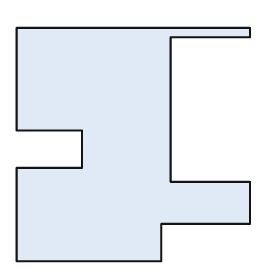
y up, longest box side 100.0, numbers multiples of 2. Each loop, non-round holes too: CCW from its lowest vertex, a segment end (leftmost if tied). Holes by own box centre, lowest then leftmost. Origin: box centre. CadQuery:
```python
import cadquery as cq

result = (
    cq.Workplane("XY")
    .moveTo(-50.0, -50.0)
    .lineTo(12.0, -50.0)
    .lineTo(12.0, -34.0)
    .lineTo(50.0, -34.0)
    .lineTo(50.0, -16.0)
    .lineTo(16.0, -16.0)
    .lineTo(16.0, 46.0)
    .lineTo(50.0, 46.0)
    .lineTo(50.0, 50.0)
    .lineTo(-50.0, 50.0)
    .lineTo(-50.0, 6.0)
    .lineTo(-22.0, 6.0)
    .lineTo(-22.0, -10.0)
    .lineTo(-50.0, -10.0)
    .close()
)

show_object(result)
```